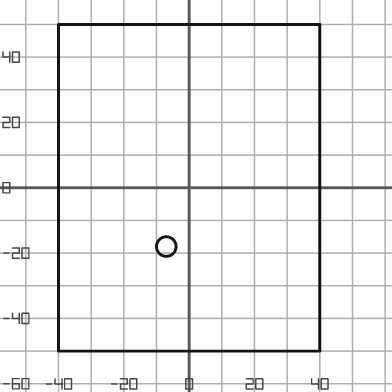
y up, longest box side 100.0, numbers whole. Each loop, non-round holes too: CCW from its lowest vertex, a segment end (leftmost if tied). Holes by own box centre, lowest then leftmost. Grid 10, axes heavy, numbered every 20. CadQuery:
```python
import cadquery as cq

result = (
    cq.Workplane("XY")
    .moveTo(-40.0, -50.0)
    .lineTo(40.0, -50.0)
    .lineTo(40.0, 50.0)
    .lineTo(-40.0, 50.0)
    .close()
    .moveTo(-7.0, -18.0)
    .circle(3.0)
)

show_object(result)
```